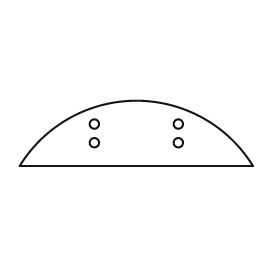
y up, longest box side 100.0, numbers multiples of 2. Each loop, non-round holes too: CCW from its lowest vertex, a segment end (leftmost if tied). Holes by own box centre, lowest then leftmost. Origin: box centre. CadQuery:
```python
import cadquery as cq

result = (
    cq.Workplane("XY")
    .moveTo(-50.0, -14.0)
    .lineTo(50.0, -14.0)
    .threePointArc((0.0, 14.0), (-50.0, -14.0))
    .close()
    .moveTo(-18.0, -4.0)
    .circle(2.0)
    .moveTo(18.0, -4.0)
    .circle(2.0)
    .moveTo(-18.0, 4.0)
    .circle(2.0)
    .moveTo(18.0, 4.0)
    .circle(2.0)
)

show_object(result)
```